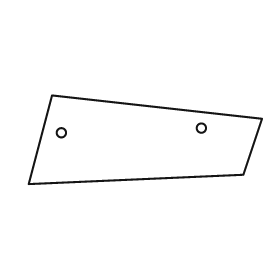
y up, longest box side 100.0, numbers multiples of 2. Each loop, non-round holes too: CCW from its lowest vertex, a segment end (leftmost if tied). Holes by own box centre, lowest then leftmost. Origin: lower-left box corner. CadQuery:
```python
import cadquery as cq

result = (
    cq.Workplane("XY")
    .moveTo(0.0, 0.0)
    .lineTo(92.0, 4.0)
    .lineTo(100.0, 28.0)
    .lineTo(10.0, 38.0)
    .close()
    .moveTo(14.0, 22.0)
    .circle(2.0)
    .moveTo(74.0, 24.0)
    .circle(2.0)
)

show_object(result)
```